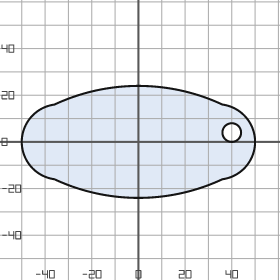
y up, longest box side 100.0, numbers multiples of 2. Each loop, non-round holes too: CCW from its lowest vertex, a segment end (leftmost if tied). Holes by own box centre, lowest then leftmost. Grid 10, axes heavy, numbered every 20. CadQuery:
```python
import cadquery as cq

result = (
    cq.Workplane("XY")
    .moveTo(-36.0, -16.0)
    .threePointArc((0.0, -24.0), (36.0, -16.0))
    .threePointArc((50.0, 0.0), (36.0, 16.0))
    .threePointArc((0.0, 24.0), (-36.0, 16.0))
    .threePointArc((-50.0, 0.0), (-36.0, -16.0))
    .close()
    .moveTo(40.0, 4.0)
    .circle(4.0)
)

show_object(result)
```